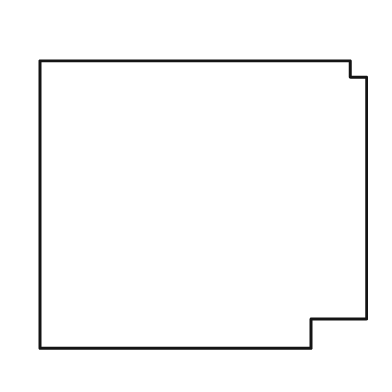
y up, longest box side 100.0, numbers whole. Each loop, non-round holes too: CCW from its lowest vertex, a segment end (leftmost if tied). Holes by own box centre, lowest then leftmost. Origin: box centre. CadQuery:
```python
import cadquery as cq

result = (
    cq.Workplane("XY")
    .moveTo(-50.0, -44.0)
    .lineTo(33.0, -44.0)
    .lineTo(33.0, -35.0)
    .lineTo(50.0, -35.0)
    .lineTo(50.0, 39.0)
    .lineTo(45.0, 39.0)
    .lineTo(45.0, 44.0)
    .lineTo(-50.0, 44.0)
    .close()
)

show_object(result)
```